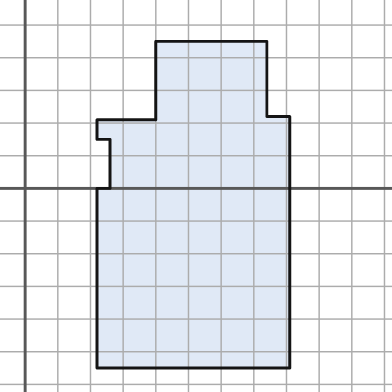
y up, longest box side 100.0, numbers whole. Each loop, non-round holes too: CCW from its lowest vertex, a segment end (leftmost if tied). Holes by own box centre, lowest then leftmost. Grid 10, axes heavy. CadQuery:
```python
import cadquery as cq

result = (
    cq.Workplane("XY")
    .moveTo(22.0, -55.0)
    .lineTo(81.0, -55.0)
    .lineTo(81.0, 22.0)
    .lineTo(74.0, 22.0)
    .lineTo(74.0, 45.0)
    .lineTo(40.0, 45.0)
    .lineTo(40.0, 21.0)
    .lineTo(22.0, 21.0)
    .lineTo(22.0, 15.0)
    .lineTo(26.0, 15.0)
    .lineTo(26.0, 0.0)
    .lineTo(22.0, 0.0)
    .close()
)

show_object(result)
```